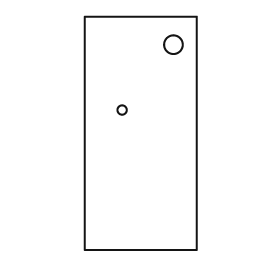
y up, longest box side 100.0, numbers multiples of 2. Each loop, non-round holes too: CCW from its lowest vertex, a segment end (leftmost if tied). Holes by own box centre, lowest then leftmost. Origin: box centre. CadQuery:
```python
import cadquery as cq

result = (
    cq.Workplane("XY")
    .moveTo(-24.0, -50.0)
    .lineTo(24.0, -50.0)
    .lineTo(24.0, 50.0)
    .lineTo(-24.0, 50.0)
    .close()
    .moveTo(-8.0, 10.0)
    .circle(2.0)
    .moveTo(14.0, 38.0)
    .circle(4.0)
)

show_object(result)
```